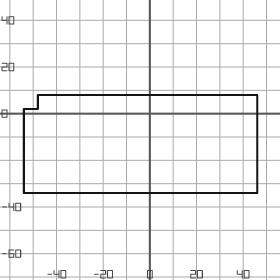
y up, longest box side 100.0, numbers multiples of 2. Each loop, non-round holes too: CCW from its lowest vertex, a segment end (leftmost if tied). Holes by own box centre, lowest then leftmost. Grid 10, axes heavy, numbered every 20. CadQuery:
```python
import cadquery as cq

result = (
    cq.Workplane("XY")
    .moveTo(-54.0, -34.0)
    .lineTo(46.0, -34.0)
    .lineTo(46.0, 8.0)
    .lineTo(-48.0, 8.0)
    .lineTo(-48.0, 2.0)
    .lineTo(-54.0, 2.0)
    .close()
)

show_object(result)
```